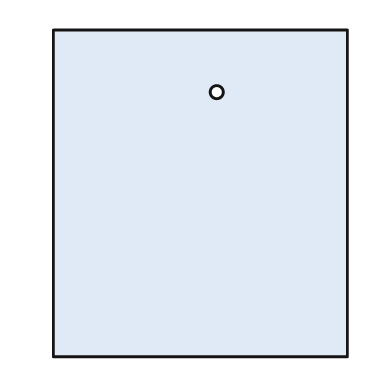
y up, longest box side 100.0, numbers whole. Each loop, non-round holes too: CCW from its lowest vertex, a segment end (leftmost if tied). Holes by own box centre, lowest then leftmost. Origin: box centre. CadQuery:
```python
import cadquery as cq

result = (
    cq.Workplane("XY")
    .moveTo(-45.0, -50.0)
    .lineTo(45.0, -50.0)
    .lineTo(45.0, 50.0)
    .lineTo(-45.0, 50.0)
    .close()
    .moveTo(5.0, 31.0)
    .circle(2.0)
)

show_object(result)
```